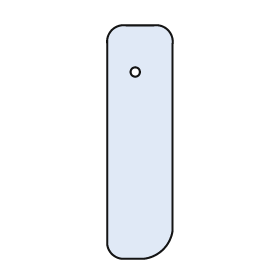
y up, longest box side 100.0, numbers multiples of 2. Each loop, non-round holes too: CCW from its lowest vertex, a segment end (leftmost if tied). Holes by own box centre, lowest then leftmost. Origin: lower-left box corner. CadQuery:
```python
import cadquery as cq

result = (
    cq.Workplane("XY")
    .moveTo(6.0, 0.0)
    .lineTo(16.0, 0.0)
    .threePointArc((24.0, 4.0), (28.0, 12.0))
    .lineTo(28.0, 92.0)
    .threePointArc((26.0, 98.0), (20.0, 100.0))
    .lineTo(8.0, 100.0)
    .threePointArc((2.0, 98.0), (0.0, 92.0))
    .lineTo(0.0, 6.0)
    .threePointArc((2.0, 2.0), (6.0, 0.0))
    .close()
    .moveTo(12.0, 80.0)
    .circle(2.0)
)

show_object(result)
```